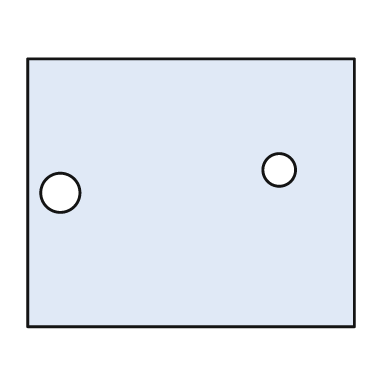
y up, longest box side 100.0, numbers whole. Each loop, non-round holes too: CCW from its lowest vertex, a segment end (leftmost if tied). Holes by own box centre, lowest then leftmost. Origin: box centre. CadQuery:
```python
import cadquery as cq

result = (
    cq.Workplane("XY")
    .moveTo(-50.0, -41.0)
    .lineTo(50.0, -41.0)
    .lineTo(50.0, 41.0)
    .lineTo(-50.0, 41.0)
    .close()
    .moveTo(-40.0, 0.0)
    .circle(6.0)
    .moveTo(27.0, 7.0)
    .circle(5.0)
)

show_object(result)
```